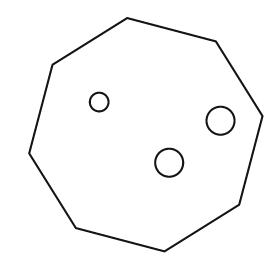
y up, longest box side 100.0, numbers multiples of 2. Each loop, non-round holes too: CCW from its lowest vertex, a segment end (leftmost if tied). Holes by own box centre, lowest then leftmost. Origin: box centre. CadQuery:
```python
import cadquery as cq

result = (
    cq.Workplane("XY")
    .moveTo(8.0, -50.0)
    .lineTo(40.0, -30.0)
    .lineTo(50.0, 8.0)
    .lineTo(30.0, 40.0)
    .lineTo(-8.0, 50.0)
    .lineTo(-40.0, 30.0)
    .lineTo(-50.0, -8.0)
    .lineTo(-30.0, -40.0)
    .close()
    .moveTo(10.0, -12.0)
    .circle(6.0)
    .moveTo(32.0, 6.0)
    .circle(6.0)
    .moveTo(-20.0, 14.0)
    .circle(4.0)
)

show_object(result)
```